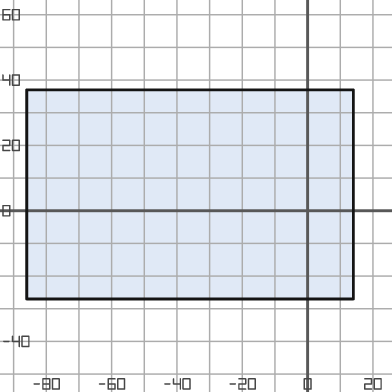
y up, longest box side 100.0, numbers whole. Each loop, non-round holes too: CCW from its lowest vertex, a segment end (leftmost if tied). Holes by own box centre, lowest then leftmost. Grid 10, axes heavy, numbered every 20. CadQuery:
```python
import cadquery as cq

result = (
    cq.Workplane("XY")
    .moveTo(-86.0, -27.0)
    .lineTo(14.0, -27.0)
    .lineTo(14.0, 37.0)
    .lineTo(-86.0, 37.0)
    .close()
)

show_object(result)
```